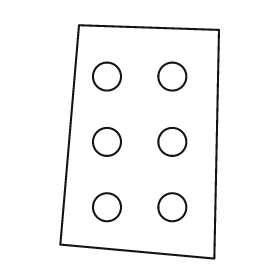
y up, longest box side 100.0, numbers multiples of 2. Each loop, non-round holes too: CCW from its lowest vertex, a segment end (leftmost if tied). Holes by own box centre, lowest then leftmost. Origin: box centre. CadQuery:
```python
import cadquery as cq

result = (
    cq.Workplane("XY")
    .moveTo(32.0, -50.0)
    .lineTo(34.0, 48.0)
    .lineTo(-26.0, 50.0)
    .lineTo(-34.0, -44.0)
    .close()
    .moveTo(-14.0, -28.0)
    .circle(6.0)
    .moveTo(14.0, -28.0)
    .circle(6.0)
    .moveTo(-14.0, 0.0)
    .circle(6.0)
    .moveTo(14.0, 0.0)
    .circle(6.0)
    .moveTo(-14.0, 28.0)
    .circle(6.0)
    .moveTo(14.0, 28.0)
    .circle(6.0)
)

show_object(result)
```